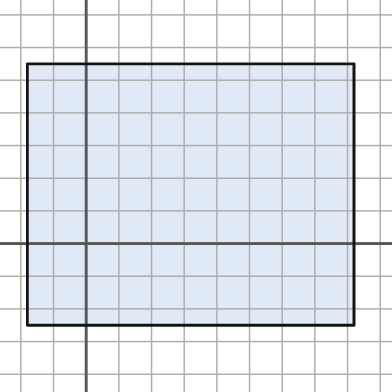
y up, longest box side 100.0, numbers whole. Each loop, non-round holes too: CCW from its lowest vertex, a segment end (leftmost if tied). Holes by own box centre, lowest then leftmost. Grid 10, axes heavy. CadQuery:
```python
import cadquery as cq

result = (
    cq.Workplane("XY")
    .moveTo(-18.0, -25.0)
    .lineTo(82.0, -25.0)
    .lineTo(82.0, 55.0)
    .lineTo(-18.0, 55.0)
    .close()
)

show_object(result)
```